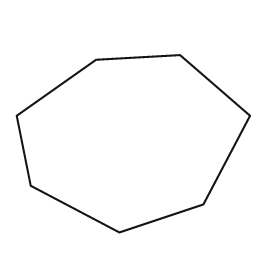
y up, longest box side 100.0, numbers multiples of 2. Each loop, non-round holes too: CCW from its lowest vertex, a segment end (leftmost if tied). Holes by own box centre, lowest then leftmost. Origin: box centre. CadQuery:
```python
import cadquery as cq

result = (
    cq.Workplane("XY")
    .moveTo(-6.0, -38.0)
    .lineTo(30.0, -26.0)
    .lineTo(50.0, 12.0)
    .lineTo(20.0, 38.0)
    .lineTo(-16.0, 36.0)
    .lineTo(-50.0, 12.0)
    .lineTo(-44.0, -18.0)
    .close()
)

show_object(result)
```